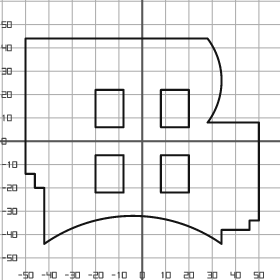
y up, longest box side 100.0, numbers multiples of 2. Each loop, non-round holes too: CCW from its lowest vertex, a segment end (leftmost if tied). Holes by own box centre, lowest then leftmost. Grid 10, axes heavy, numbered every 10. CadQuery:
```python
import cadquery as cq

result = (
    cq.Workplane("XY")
    .moveTo(-42.0, -44.0)
    .threePointArc((-4.0, -32.0), (34.0, -44.0))
    .lineTo(34.0, -38.0)
    .lineTo(46.0, -38.0)
    .lineTo(46.0, -34.0)
    .lineTo(50.0, -34.0)
    .lineTo(50.0, 8.0)
    .lineTo(28.0, 8.0)
    .threePointArc((34.0, 26.0), (28.0, 44.0))
    .lineTo(-50.0, 44.0)
    .lineTo(-50.0, -14.0)
    .lineTo(-46.0, -14.0)
    .lineTo(-46.0, -20.0)
    .lineTo(-42.0, -20.0)
    .close()
    .moveTo(-20.0, -22.0)
    .lineTo(-8.0, -22.0)
    .lineTo(-8.0, -6.0)
    .lineTo(-20.0, -6.0)
    .close()
    .moveTo(8.0, -22.0)
    .lineTo(20.0, -22.0)
    .lineTo(20.0, -6.0)
    .lineTo(8.0, -6.0)
    .close()
    .moveTo(-20.0, 6.0)
    .lineTo(-8.0, 6.0)
    .lineTo(-8.0, 22.0)
    .lineTo(-20.0, 22.0)
    .close()
    .moveTo(8.0, 6.0)
    .lineTo(20.0, 6.0)
    .lineTo(20.0, 22.0)
    .lineTo(8.0, 22.0)
    .close()
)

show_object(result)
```